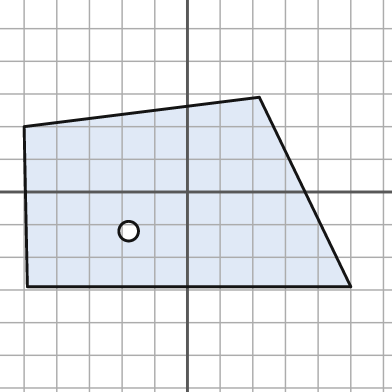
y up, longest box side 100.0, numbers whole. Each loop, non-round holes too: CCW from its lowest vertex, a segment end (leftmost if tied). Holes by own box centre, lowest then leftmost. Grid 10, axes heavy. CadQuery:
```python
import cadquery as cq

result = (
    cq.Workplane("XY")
    .moveTo(-49.0, -29.0)
    .lineTo(50.0, -29.0)
    .lineTo(22.0, 29.0)
    .lineTo(-50.0, 20.0)
    .close()
    .moveTo(-18.0, -12.0)
    .circle(3.0)
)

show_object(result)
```